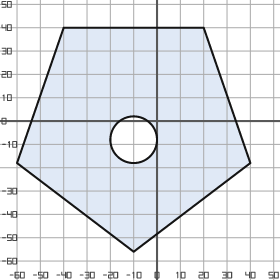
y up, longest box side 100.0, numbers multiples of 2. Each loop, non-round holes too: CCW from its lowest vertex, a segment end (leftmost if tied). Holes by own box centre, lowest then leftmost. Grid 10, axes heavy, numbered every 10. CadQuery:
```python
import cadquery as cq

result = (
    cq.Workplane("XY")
    .moveTo(-10.0, -56.0)
    .lineTo(40.0, -18.0)
    .lineTo(20.0, 40.0)
    .lineTo(-40.0, 40.0)
    .lineTo(-60.0, -18.0)
    .close()
    .moveTo(-10.0, -8.0)
    .circle(10.0)
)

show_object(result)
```